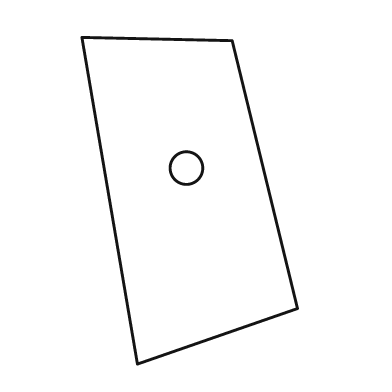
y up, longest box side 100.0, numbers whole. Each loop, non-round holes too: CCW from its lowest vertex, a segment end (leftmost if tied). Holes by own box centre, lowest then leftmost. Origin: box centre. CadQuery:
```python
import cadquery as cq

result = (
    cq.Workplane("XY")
    .moveTo(-16.0, -50.0)
    .lineTo(33.0, -33.0)
    .lineTo(13.0, 49.0)
    .lineTo(-33.0, 50.0)
    .close()
    .moveTo(-1.0, 10.0)
    .circle(5.0)
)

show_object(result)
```